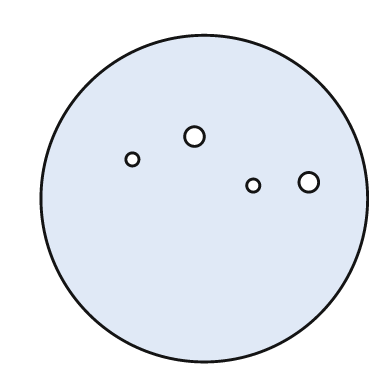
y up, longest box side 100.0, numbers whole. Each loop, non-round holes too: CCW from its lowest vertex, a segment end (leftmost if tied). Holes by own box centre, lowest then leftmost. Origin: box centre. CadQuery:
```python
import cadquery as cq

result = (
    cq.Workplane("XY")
    .moveTo(0.0, 0.0)
    .circle(50.0)
    .moveTo(15.0, 4.0)
    .circle(2.0)
    .moveTo(32.0, 5.0)
    .circle(3.0)
    .moveTo(-22.0, 12.0)
    .circle(2.0)
    .moveTo(-3.0, 19.0)
    .circle(3.0)
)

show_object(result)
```